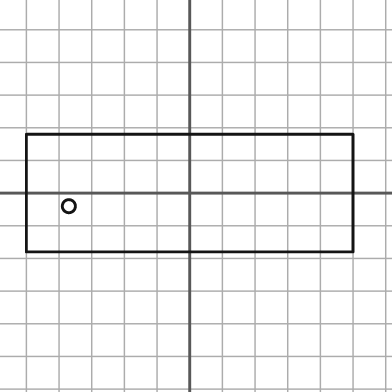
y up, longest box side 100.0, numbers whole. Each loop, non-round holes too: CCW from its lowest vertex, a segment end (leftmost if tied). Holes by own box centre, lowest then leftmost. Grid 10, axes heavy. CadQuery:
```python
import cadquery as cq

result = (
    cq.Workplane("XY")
    .moveTo(-50.0, -18.0)
    .lineTo(50.0, -18.0)
    .lineTo(50.0, 18.0)
    .lineTo(-50.0, 18.0)
    .close()
    .moveTo(-37.0, -4.0)
    .circle(2.0)
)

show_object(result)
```